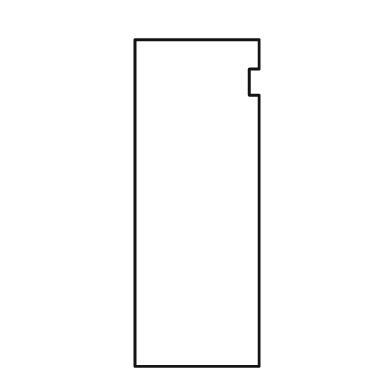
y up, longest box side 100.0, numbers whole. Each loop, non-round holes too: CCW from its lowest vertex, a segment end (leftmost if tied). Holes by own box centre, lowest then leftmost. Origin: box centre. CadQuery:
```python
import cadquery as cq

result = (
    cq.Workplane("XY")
    .moveTo(-19.0, -50.0)
    .lineTo(19.0, -50.0)
    .lineTo(19.0, 33.0)
    .lineTo(16.0, 33.0)
    .lineTo(16.0, 41.0)
    .lineTo(19.0, 41.0)
    .lineTo(19.0, 50.0)
    .lineTo(-19.0, 50.0)
    .close()
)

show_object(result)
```